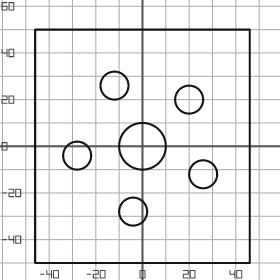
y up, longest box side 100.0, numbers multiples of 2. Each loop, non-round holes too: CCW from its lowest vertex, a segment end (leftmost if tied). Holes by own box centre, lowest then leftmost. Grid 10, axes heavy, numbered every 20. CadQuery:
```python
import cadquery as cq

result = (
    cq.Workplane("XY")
    .moveTo(-46.0, -50.0)
    .lineTo(46.0, -50.0)
    .lineTo(46.0, 50.0)
    .lineTo(-46.0, 50.0)
    .close()
    .moveTo(-4.0, -28.0)
    .circle(6.0)
    .moveTo(26.0, -12.0)
    .circle(6.0)
    .moveTo(-28.0, -4.0)
    .circle(6.0)
    .moveTo(0.0, 0.0)
    .circle(10.0)
    .moveTo(20.0, 20.0)
    .circle(6.0)
    .moveTo(-12.0, 26.0)
    .circle(6.0)
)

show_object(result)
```